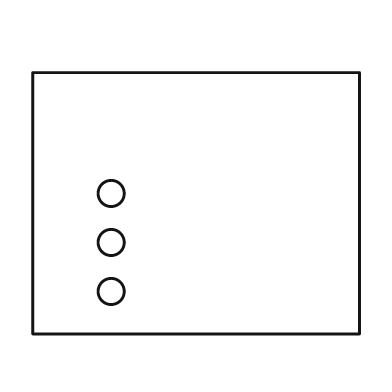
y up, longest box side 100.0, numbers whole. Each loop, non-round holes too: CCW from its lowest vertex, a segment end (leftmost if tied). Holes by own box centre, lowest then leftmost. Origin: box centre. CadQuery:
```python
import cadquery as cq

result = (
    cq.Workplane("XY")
    .moveTo(-50.0, -40.0)
    .lineTo(50.0, -40.0)
    .lineTo(50.0, 40.0)
    .lineTo(-50.0, 40.0)
    .close()
    .moveTo(-26.0, -27.0)
    .circle(4.0)
    .moveTo(-26.0, -12.0)
    .circle(4.0)
    .moveTo(-26.0, 3.0)
    .circle(4.0)
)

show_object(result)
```